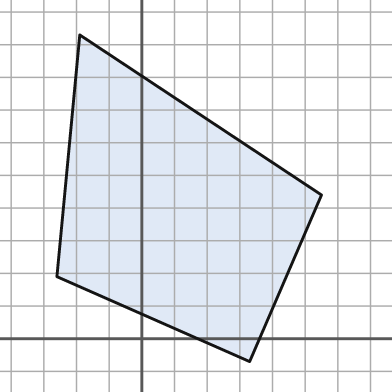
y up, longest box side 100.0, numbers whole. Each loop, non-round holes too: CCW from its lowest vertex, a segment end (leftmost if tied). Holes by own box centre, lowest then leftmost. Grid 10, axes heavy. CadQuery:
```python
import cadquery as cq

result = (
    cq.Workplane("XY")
    .moveTo(33.0, -7.0)
    .lineTo(55.0, 44.0)
    .lineTo(-19.0, 93.0)
    .lineTo(-26.0, 19.0)
    .close()
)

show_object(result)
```